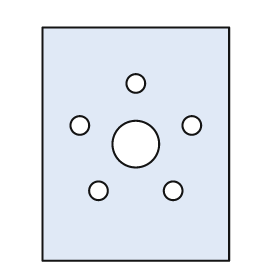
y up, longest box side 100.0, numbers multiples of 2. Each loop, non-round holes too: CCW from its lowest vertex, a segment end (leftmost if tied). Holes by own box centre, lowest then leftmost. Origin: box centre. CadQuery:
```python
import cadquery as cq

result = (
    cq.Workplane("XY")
    .moveTo(-40.0, -50.0)
    .lineTo(40.0, -50.0)
    .lineTo(40.0, 50.0)
    .lineTo(-40.0, 50.0)
    .close()
    .moveTo(-16.0, -20.0)
    .circle(4.0)
    .moveTo(16.0, -20.0)
    .circle(4.0)
    .moveTo(0.0, 0.0)
    .circle(10.0)
    .moveTo(-24.0, 8.0)
    .circle(4.0)
    .moveTo(24.0, 8.0)
    .circle(4.0)
    .moveTo(0.0, 26.0)
    .circle(4.0)
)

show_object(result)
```